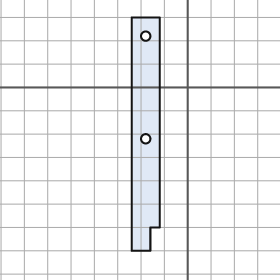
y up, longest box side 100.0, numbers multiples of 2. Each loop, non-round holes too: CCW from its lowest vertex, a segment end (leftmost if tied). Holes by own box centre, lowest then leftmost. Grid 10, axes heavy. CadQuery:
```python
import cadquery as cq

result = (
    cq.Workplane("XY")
    .moveTo(-24.0, -70.0)
    .lineTo(-16.0, -70.0)
    .lineTo(-16.0, -60.0)
    .lineTo(-12.0, -60.0)
    .lineTo(-12.0, 30.0)
    .lineTo(-24.0, 30.0)
    .close()
    .moveTo(-18.0, -22.0)
    .circle(2.0)
    .moveTo(-18.0, 22.0)
    .circle(2.0)
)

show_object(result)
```